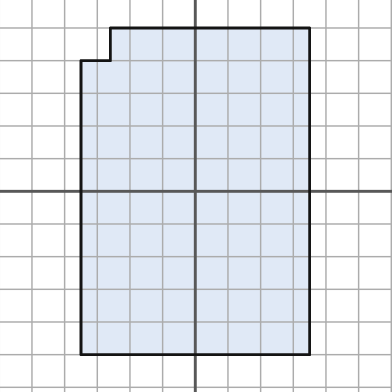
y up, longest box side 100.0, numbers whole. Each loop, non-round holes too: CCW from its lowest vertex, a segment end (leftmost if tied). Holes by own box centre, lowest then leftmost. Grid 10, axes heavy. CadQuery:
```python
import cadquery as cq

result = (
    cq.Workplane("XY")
    .moveTo(-35.0, -50.0)
    .lineTo(35.0, -50.0)
    .lineTo(35.0, 50.0)
    .lineTo(-26.0, 50.0)
    .lineTo(-26.0, 40.0)
    .lineTo(-35.0, 40.0)
    .close()
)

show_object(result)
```